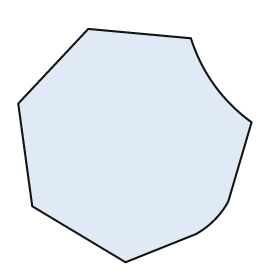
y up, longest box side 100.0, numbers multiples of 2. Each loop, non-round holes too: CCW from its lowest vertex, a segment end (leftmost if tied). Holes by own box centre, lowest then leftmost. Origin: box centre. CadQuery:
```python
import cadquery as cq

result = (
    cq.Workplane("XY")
    .moveTo(-4.0, -50.0)
    .lineTo(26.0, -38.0)
    .threePointArc((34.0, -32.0), (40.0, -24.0))
    .lineTo(50.0, 10.0)
    .threePointArc((34.0, 26.0), (24.0, 46.0))
    .lineTo(-20.0, 50.0)
    .lineTo(-50.0, 18.0)
    .lineTo(-44.0, -26.0)
    .close()
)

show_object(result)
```